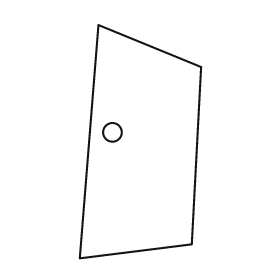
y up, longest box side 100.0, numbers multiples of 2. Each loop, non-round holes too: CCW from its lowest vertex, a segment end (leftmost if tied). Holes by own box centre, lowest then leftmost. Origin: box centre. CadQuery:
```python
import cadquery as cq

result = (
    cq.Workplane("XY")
    .moveTo(-26.0, -50.0)
    .lineTo(22.0, -44.0)
    .lineTo(26.0, 32.0)
    .lineTo(-18.0, 50.0)
    .close()
    .moveTo(-12.0, 4.0)
    .circle(4.0)
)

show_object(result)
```